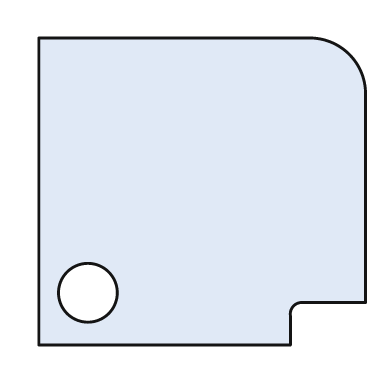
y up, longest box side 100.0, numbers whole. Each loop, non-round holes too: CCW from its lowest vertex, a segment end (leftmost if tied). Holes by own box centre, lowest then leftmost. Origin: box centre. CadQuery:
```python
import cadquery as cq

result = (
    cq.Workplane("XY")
    .moveTo(-50.0, -47.0)
    .lineTo(27.0, -47.0)
    .lineTo(27.0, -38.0)
    .threePointArc((28.0, -35.0), (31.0, -34.0))
    .lineTo(50.0, -34.0)
    .lineTo(50.0, 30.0)
    .threePointArc((45.0, 42.0), (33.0, 47.0))
    .lineTo(-50.0, 47.0)
    .close()
    .moveTo(-35.0, -31.0)
    .circle(9.0)
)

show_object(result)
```